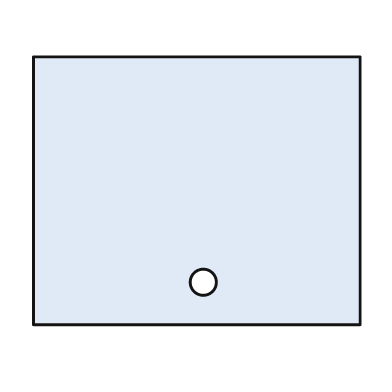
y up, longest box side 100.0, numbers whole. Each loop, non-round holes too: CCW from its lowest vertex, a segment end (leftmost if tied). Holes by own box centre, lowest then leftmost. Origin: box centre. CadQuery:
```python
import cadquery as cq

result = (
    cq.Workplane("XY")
    .moveTo(-50.0, -41.0)
    .lineTo(50.0, -41.0)
    .lineTo(50.0, 41.0)
    .lineTo(-50.0, 41.0)
    .close()
    .moveTo(2.0, -28.0)
    .circle(4.0)
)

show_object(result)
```